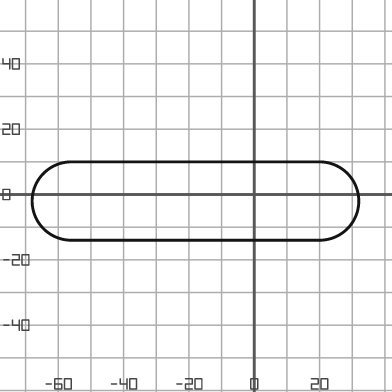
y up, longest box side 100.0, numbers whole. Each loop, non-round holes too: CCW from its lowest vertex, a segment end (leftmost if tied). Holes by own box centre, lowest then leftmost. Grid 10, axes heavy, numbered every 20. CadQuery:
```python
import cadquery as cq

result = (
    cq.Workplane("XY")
    .moveTo(-56.0, -14.0)
    .lineTo(20.0, -14.0)
    .threePointArc((32.0, -2.0), (20.0, 10.0))
    .lineTo(-56.0, 10.0)
    .threePointArc((-68.0, -2.0), (-56.0, -14.0))
    .close()
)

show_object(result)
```